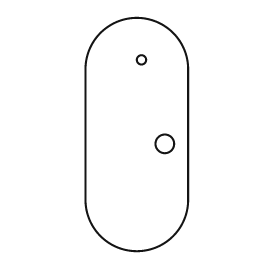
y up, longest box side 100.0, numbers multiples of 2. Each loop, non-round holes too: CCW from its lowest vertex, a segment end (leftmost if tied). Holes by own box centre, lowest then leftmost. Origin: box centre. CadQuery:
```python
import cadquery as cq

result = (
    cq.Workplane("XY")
    .moveTo(-22.0, -28.0)
    .threePointArc((0.0, -50.0), (22.0, -28.0))
    .lineTo(22.0, 28.0)
    .threePointArc((0.0, 50.0), (-22.0, 28.0))
    .close()
    .moveTo(12.0, -4.0)
    .circle(4.0)
    .moveTo(2.0, 32.0)
    .circle(2.0)
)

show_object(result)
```